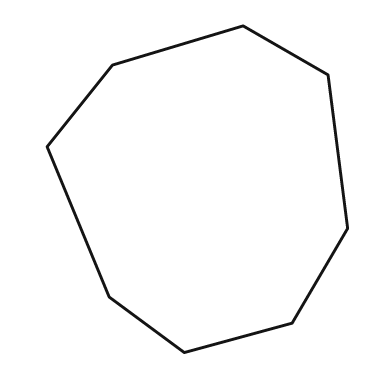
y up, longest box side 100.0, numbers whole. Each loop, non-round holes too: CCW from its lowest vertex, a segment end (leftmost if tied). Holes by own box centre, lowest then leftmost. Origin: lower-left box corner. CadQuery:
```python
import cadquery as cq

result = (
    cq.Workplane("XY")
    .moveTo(42.0, 0.0)
    .lineTo(75.0, 9.0)
    .lineTo(92.0, 38.0)
    .lineTo(86.0, 85.0)
    .lineTo(60.0, 100.0)
    .lineTo(20.0, 88.0)
    .lineTo(0.0, 63.0)
    .lineTo(19.0, 17.0)
    .close()
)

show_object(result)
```